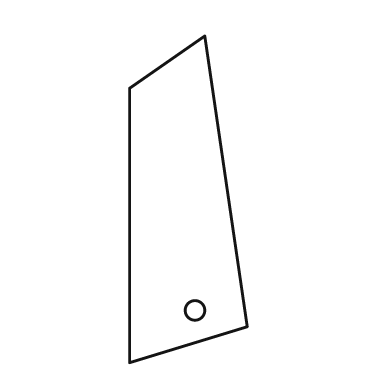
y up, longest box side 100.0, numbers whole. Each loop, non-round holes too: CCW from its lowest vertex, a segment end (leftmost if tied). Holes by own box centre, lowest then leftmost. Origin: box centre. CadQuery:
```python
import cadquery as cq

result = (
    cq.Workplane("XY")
    .moveTo(-18.0, -50.0)
    .lineTo(18.0, -39.0)
    .lineTo(5.0, 50.0)
    .lineTo(-18.0, 34.0)
    .close()
    .moveTo(2.0, -34.0)
    .circle(3.0)
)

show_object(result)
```